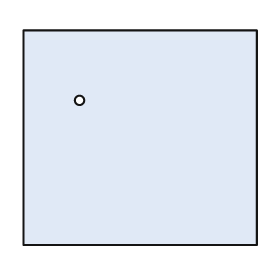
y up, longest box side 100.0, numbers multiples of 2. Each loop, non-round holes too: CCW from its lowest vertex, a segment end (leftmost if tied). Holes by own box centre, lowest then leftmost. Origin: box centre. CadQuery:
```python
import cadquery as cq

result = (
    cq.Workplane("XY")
    .moveTo(-50.0, -46.0)
    .lineTo(50.0, -46.0)
    .lineTo(50.0, 46.0)
    .lineTo(-50.0, 46.0)
    .close()
    .moveTo(-26.0, 16.0)
    .circle(2.0)
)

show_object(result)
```